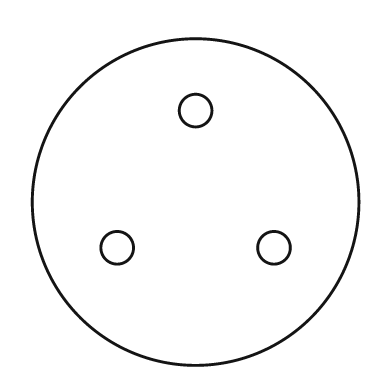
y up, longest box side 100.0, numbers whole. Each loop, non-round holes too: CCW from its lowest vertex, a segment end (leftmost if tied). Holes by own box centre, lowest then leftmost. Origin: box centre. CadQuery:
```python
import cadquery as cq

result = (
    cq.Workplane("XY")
    .moveTo(0.0, 0.0)
    .circle(50.0)
    .moveTo(-24.0, -14.0)
    .circle(5.0)
    .moveTo(24.0, -14.0)
    .circle(5.0)
    .moveTo(0.0, 28.0)
    .circle(5.0)
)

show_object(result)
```